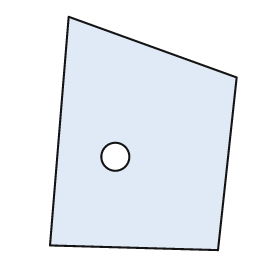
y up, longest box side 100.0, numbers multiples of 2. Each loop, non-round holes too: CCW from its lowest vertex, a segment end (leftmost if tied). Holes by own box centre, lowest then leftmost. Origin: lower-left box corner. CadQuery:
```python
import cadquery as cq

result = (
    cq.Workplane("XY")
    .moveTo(72.0, 0.0)
    .lineTo(80.0, 74.0)
    .lineTo(8.0, 100.0)
    .lineTo(0.0, 2.0)
    .close()
    .moveTo(28.0, 40.0)
    .circle(6.0)
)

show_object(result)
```